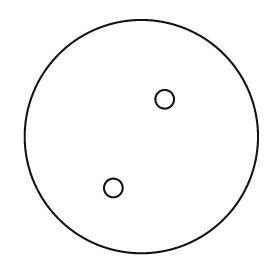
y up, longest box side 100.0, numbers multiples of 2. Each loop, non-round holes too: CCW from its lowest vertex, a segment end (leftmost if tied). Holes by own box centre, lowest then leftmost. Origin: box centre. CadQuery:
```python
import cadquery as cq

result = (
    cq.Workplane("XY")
    .moveTo(0.0, 0.0)
    .circle(50.0)
    .moveTo(-12.0, -22.0)
    .circle(4.0)
    .moveTo(10.0, 16.0)
    .circle(4.0)
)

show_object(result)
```